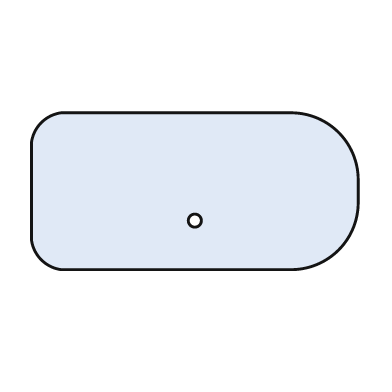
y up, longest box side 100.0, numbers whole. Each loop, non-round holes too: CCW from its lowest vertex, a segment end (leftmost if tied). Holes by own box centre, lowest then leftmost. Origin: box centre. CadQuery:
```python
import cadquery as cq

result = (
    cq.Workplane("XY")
    .moveTo(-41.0, -24.0)
    .lineTo(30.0, -24.0)
    .threePointArc((44.0, -18.0), (50.0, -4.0))
    .lineTo(50.0, 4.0)
    .threePointArc((44.0, 18.0), (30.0, 24.0))
    .lineTo(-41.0, 24.0)
    .threePointArc((-47.0, 21.0), (-50.0, 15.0))
    .lineTo(-50.0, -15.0)
    .threePointArc((-47.0, -21.0), (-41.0, -24.0))
    .close()
    .moveTo(0.0, -9.0)
    .circle(2.0)
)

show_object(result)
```